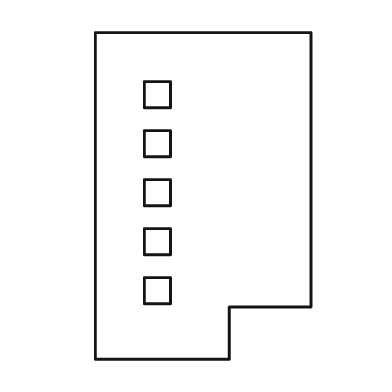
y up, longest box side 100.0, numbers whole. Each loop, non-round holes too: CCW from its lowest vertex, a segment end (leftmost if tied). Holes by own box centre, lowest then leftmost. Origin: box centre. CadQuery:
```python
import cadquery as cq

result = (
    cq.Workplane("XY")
    .moveTo(-33.0, -50.0)
    .lineTo(8.0, -50.0)
    .lineTo(8.0, -34.0)
    .lineTo(33.0, -34.0)
    .lineTo(33.0, 50.0)
    .lineTo(-33.0, 50.0)
    .close()
    .moveTo(-18.0, -33.0)
    .lineTo(-10.0, -33.0)
    .lineTo(-10.0, -25.0)
    .lineTo(-18.0, -25.0)
    .close()
    .moveTo(-18.0, -18.0)
    .lineTo(-10.0, -18.0)
    .lineTo(-10.0, -10.0)
    .lineTo(-18.0, -10.0)
    .close()
    .moveTo(-18.0, -3.0)
    .lineTo(-10.0, -3.0)
    .lineTo(-10.0, 5.0)
    .lineTo(-18.0, 5.0)
    .close()
    .moveTo(-18.0, 12.0)
    .lineTo(-10.0, 12.0)
    .lineTo(-10.0, 20.0)
    .lineTo(-18.0, 20.0)
    .close()
    .moveTo(-18.0, 27.0)
    .lineTo(-10.0, 27.0)
    .lineTo(-10.0, 35.0)
    .lineTo(-18.0, 35.0)
    .close()
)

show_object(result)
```